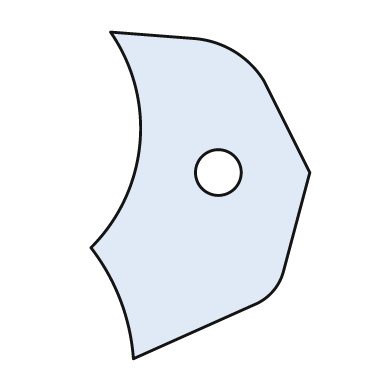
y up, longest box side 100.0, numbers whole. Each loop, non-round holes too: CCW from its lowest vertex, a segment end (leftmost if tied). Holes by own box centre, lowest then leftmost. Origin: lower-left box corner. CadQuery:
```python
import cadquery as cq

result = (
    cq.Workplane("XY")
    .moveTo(13.0, 0.0)
    .lineTo(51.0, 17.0)
    .threePointArc((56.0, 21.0), (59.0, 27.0))
    .lineTo(67.0, 57.0)
    .lineTo(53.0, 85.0)
    .threePointArc((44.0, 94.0), (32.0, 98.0))
    .lineTo(6.0, 100.0)
    .threePointArc((15.0, 66.0), (0.0, 34.0))
    .threePointArc((9.0, 18.0), (13.0, 0.0))
    .close()
    .moveTo(39.0, 57.0)
    .circle(7.0)
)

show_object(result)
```